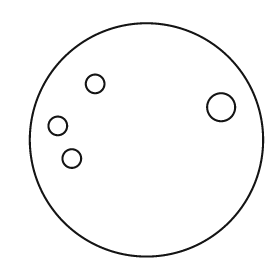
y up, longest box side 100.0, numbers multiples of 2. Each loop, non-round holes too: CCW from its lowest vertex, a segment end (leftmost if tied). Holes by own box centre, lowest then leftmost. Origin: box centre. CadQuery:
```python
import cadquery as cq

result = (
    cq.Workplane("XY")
    .moveTo(0.0, 0.0)
    .circle(50.0)
    .moveTo(-32.0, -8.0)
    .circle(4.0)
    .moveTo(-38.0, 6.0)
    .circle(4.0)
    .moveTo(32.0, 14.0)
    .circle(6.0)
    .moveTo(-22.0, 24.0)
    .circle(4.0)
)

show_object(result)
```